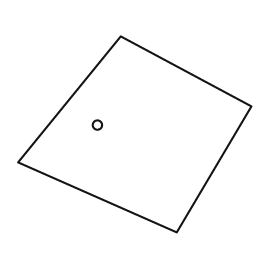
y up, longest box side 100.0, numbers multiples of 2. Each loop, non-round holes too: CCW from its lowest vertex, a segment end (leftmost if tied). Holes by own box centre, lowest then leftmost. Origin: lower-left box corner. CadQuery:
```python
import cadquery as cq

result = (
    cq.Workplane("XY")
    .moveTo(68.0, 0.0)
    .lineTo(100.0, 54.0)
    .lineTo(44.0, 84.0)
    .lineTo(0.0, 30.0)
    .close()
    .moveTo(34.0, 46.0)
    .circle(2.0)
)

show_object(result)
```